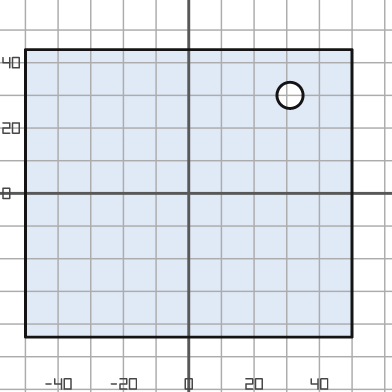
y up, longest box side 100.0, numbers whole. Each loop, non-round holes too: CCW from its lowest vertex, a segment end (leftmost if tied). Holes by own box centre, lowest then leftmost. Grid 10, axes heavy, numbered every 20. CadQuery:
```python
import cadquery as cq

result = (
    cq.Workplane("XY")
    .moveTo(-50.0, -44.0)
    .lineTo(50.0, -44.0)
    .lineTo(50.0, 44.0)
    .lineTo(-50.0, 44.0)
    .close()
    .moveTo(31.0, 30.0)
    .circle(4.0)
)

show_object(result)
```